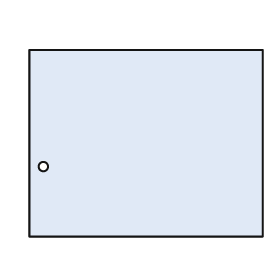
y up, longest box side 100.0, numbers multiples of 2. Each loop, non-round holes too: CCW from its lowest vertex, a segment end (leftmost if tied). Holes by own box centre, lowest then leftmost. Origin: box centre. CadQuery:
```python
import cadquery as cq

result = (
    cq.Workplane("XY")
    .moveTo(-50.0, -40.0)
    .lineTo(50.0, -40.0)
    .lineTo(50.0, 40.0)
    .lineTo(-50.0, 40.0)
    .close()
    .moveTo(-44.0, -10.0)
    .circle(2.0)
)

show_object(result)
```